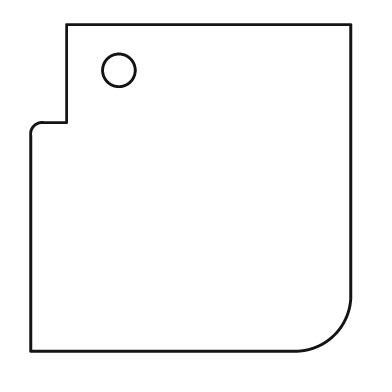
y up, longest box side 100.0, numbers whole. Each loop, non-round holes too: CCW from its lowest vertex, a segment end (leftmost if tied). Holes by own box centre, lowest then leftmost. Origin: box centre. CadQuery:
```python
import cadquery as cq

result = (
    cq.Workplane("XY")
    .moveTo(-49.0, -50.0)
    .lineTo(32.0, -50.0)
    .threePointArc((44.0, -45.0), (49.0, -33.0))
    .lineTo(49.0, 50.0)
    .lineTo(-38.0, 50.0)
    .lineTo(-38.0, 20.0)
    .lineTo(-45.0, 20.0)
    .threePointArc((-48.0, 19.0), (-49.0, 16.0))
    .close()
    .moveTo(-22.0, 36.0)
    .circle(5.0)
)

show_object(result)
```